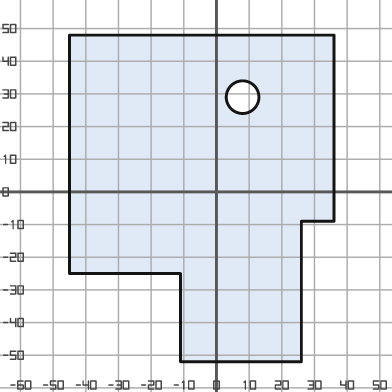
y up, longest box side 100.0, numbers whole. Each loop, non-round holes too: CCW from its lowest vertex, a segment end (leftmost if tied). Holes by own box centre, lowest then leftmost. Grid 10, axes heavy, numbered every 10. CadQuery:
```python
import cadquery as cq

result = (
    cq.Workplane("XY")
    .moveTo(-11.0, -52.0)
    .lineTo(26.0, -52.0)
    .lineTo(26.0, -9.0)
    .lineTo(36.0, -9.0)
    .lineTo(36.0, 48.0)
    .lineTo(-45.0, 48.0)
    .lineTo(-45.0, -25.0)
    .lineTo(-11.0, -25.0)
    .close()
    .moveTo(8.0, 29.0)
    .circle(5.0)
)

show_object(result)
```